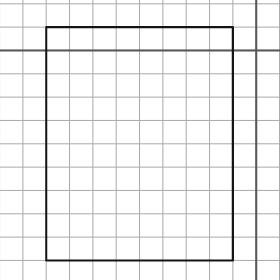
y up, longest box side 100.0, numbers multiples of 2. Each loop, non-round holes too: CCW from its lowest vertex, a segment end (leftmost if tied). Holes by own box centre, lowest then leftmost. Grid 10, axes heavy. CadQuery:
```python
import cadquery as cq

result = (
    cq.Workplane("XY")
    .moveTo(-90.0, -90.0)
    .lineTo(-10.0, -90.0)
    .lineTo(-10.0, 10.0)
    .lineTo(-90.0, 10.0)
    .close()
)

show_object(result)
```